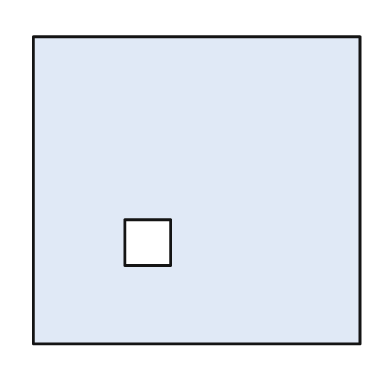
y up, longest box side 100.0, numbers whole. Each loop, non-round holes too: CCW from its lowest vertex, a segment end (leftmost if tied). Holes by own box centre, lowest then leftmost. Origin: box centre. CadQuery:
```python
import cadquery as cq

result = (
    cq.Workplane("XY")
    .moveTo(-50.0, -47.0)
    .lineTo(50.0, -47.0)
    .lineTo(50.0, 47.0)
    .lineTo(-50.0, 47.0)
    .close()
    .moveTo(-22.0, -23.0)
    .lineTo(-8.0, -23.0)
    .lineTo(-8.0, -9.0)
    .lineTo(-22.0, -9.0)
    .close()
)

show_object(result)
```